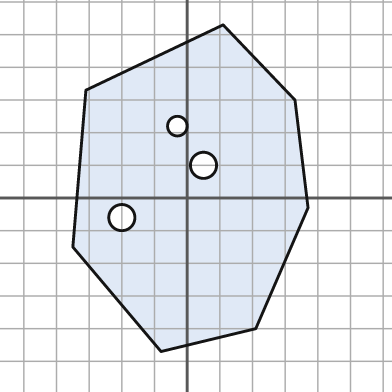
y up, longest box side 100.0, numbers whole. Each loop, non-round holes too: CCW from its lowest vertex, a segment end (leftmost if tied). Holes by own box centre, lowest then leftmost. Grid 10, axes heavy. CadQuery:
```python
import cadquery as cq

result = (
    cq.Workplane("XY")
    .moveTo(-8.0, -47.0)
    .lineTo(21.0, -40.0)
    .lineTo(37.0, -3.0)
    .lineTo(33.0, 30.0)
    .lineTo(11.0, 53.0)
    .lineTo(-31.0, 33.0)
    .lineTo(-35.0, -15.0)
    .close()
    .moveTo(-20.0, -6.0)
    .circle(4.0)
    .moveTo(5.0, 10.0)
    .circle(4.0)
    .moveTo(-3.0, 22.0)
    .circle(3.0)
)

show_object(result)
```